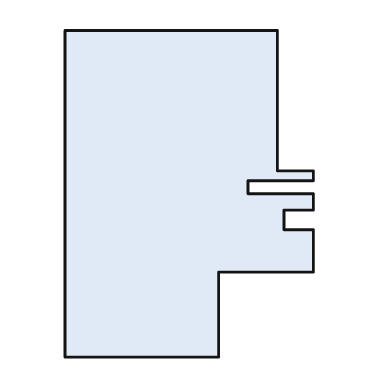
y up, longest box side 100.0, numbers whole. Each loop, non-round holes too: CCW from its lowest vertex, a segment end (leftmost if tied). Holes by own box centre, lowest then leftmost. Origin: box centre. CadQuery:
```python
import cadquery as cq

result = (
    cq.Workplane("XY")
    .moveTo(-38.0, -50.0)
    .lineTo(9.0, -50.0)
    .lineTo(9.0, -24.0)
    .lineTo(38.0, -24.0)
    .lineTo(38.0, -11.0)
    .lineTo(29.0, -11.0)
    .lineTo(29.0, -5.0)
    .lineTo(38.0, -5.0)
    .lineTo(38.0, 0.0)
    .lineTo(18.0, 0.0)
    .lineTo(18.0, 4.0)
    .lineTo(38.0, 4.0)
    .lineTo(38.0, 7.0)
    .lineTo(27.0, 7.0)
    .lineTo(27.0, 50.0)
    .lineTo(-38.0, 50.0)
    .close()
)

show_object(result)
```